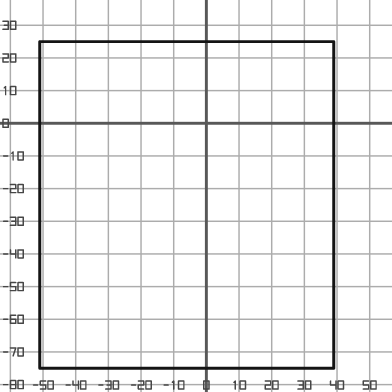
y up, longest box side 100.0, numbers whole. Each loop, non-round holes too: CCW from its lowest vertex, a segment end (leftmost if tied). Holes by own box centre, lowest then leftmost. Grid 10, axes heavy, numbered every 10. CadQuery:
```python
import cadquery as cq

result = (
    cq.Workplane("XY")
    .moveTo(-51.0, -75.0)
    .lineTo(39.0, -75.0)
    .lineTo(39.0, 25.0)
    .lineTo(-51.0, 25.0)
    .close()
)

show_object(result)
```